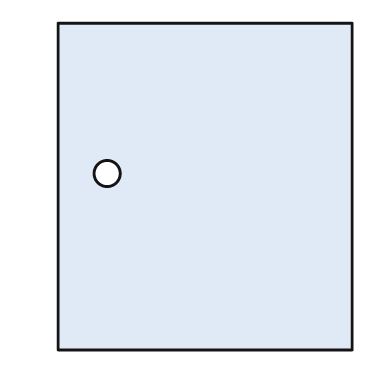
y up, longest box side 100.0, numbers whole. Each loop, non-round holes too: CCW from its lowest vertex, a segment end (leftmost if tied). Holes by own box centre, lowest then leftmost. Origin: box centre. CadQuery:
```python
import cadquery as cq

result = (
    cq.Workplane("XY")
    .moveTo(-45.0, -50.0)
    .lineTo(45.0, -50.0)
    .lineTo(45.0, 50.0)
    .lineTo(-45.0, 50.0)
    .close()
    .moveTo(-30.0, 4.0)
    .circle(4.0)
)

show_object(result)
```